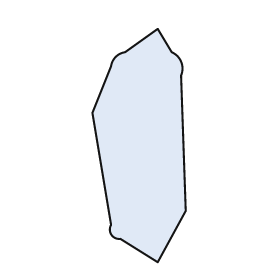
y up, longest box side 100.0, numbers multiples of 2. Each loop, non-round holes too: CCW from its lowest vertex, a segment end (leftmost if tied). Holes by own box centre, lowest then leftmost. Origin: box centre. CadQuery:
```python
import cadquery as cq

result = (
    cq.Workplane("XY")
    .moveTo(8.0, -50.0)
    .lineTo(20.0, -28.0)
    .lineTo(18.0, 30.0)
    .threePointArc((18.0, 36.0), (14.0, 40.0))
    .lineTo(8.0, 50.0)
    .lineTo(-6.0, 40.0)
    .threePointArc((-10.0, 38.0), (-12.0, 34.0))
    .lineTo(-20.0, 14.0)
    .lineTo(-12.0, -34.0)
    .threePointArc((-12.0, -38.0), (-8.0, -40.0))
    .close()
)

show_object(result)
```